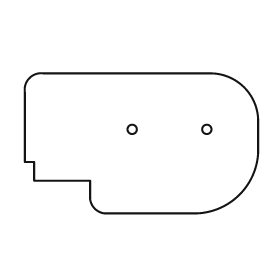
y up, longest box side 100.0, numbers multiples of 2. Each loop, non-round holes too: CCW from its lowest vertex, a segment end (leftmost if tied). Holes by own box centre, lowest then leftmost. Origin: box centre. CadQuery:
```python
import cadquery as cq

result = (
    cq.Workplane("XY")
    .moveTo(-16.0, -30.0)
    .lineTo(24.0, -30.0)
    .threePointArc((42.0, -22.0), (50.0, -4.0))
    .lineTo(50.0, 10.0)
    .threePointArc((44.0, 24.0), (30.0, 30.0))
    .lineTo(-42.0, 30.0)
    .threePointArc((-48.0, 28.0), (-50.0, 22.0))
    .lineTo(-50.0, -8.0)
    .lineTo(-46.0, -8.0)
    .lineTo(-46.0, -16.0)
    .lineTo(-22.0, -16.0)
    .lineTo(-22.0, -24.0)
    .threePointArc((-20.0, -28.0), (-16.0, -30.0))
    .close()
    .moveTo(-4.0, 6.0)
    .circle(2.0)
    .moveTo(28.0, 6.0)
    .circle(2.0)
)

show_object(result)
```